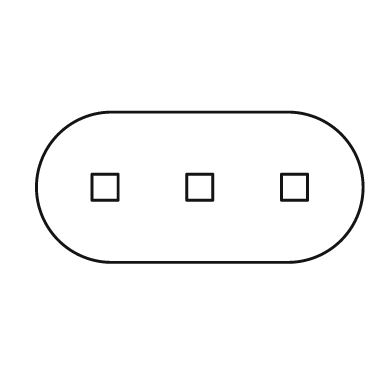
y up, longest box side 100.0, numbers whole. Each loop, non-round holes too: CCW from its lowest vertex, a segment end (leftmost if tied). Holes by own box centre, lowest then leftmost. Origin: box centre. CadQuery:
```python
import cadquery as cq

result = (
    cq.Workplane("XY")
    .moveTo(-27.0, -23.0)
    .lineTo(27.0, -23.0)
    .threePointArc((50.0, 0.0), (27.0, 23.0))
    .lineTo(-27.0, 23.0)
    .threePointArc((-50.0, 0.0), (-27.0, -23.0))
    .close()
    .moveTo(-33.0, -4.0)
    .lineTo(-25.0, -4.0)
    .lineTo(-25.0, 4.0)
    .lineTo(-33.0, 4.0)
    .close()
    .moveTo(-4.0, -4.0)
    .lineTo(4.0, -4.0)
    .lineTo(4.0, 4.0)
    .lineTo(-4.0, 4.0)
    .close()
    .moveTo(25.0, -4.0)
    .lineTo(33.0, -4.0)
    .lineTo(33.0, 4.0)
    .lineTo(25.0, 4.0)
    .close()
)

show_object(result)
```